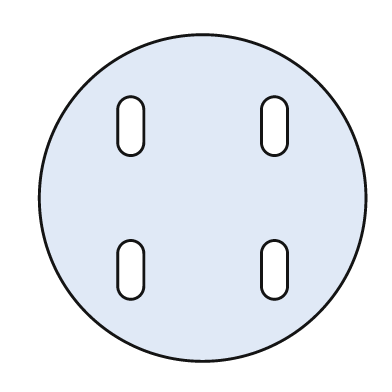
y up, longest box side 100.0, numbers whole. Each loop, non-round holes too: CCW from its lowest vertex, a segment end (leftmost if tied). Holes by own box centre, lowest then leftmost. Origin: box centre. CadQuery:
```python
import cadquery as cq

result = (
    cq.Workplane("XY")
    .moveTo(0.0, 0.0)
    .circle(50.0)
    .moveTo(-26.0, -27.0)
    .threePointArc((-22.0, -31.0), (-18.0, -27.0))
    .lineTo(-18.0, -17.0)
    .threePointArc((-22.0, -13.0), (-26.0, -17.0))
    .close()
    .moveTo(18.0, -27.0)
    .threePointArc((22.0, -31.0), (26.0, -27.0))
    .lineTo(26.0, -17.0)
    .threePointArc((22.0, -13.0), (18.0, -17.0))
    .close()
    .moveTo(-26.0, 17.0)
    .threePointArc((-22.0, 13.0), (-18.0, 17.0))
    .lineTo(-18.0, 27.0)
    .threePointArc((-22.0, 31.0), (-26.0, 27.0))
    .close()
    .moveTo(18.0, 17.0)
    .threePointArc((22.0, 13.0), (26.0, 17.0))
    .lineTo(26.0, 27.0)
    .threePointArc((22.0, 31.0), (18.0, 27.0))
    .close()
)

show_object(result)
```